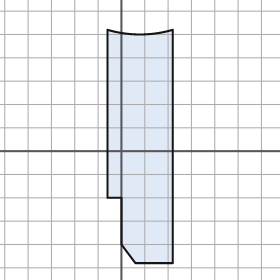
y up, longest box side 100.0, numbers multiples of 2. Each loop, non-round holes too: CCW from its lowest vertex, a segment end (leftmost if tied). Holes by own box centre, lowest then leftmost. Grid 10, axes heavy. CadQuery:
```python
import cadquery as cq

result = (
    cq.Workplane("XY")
    .moveTo(6.0, -48.0)
    .lineTo(22.0, -48.0)
    .lineTo(22.0, 52.0)
    .threePointArc((8.0, 50.0), (-6.0, 52.0))
    .lineTo(-6.0, -20.0)
    .lineTo(0.0, -20.0)
    .lineTo(0.0, -40.0)
    .close()
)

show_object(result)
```